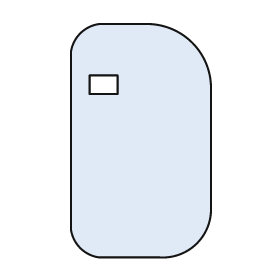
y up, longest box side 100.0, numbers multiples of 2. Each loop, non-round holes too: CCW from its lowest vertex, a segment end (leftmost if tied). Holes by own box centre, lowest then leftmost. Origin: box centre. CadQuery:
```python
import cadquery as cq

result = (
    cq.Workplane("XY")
    .moveTo(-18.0, -50.0)
    .lineTo(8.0, -50.0)
    .threePointArc((24.0, -44.0), (30.0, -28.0))
    .lineTo(30.0, 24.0)
    .threePointArc((22.0, 42.0), (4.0, 50.0))
    .lineTo(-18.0, 50.0)
    .threePointArc((-26.0, 46.0), (-30.0, 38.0))
    .lineTo(-30.0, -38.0)
    .threePointArc((-26.0, -46.0), (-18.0, -50.0))
    .close()
    .moveTo(-22.0, 20.0)
    .lineTo(-10.0, 20.0)
    .lineTo(-10.0, 28.0)
    .lineTo(-22.0, 28.0)
    .close()
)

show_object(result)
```